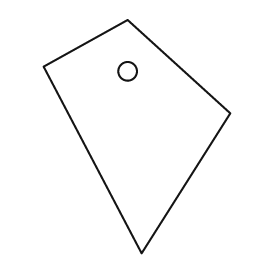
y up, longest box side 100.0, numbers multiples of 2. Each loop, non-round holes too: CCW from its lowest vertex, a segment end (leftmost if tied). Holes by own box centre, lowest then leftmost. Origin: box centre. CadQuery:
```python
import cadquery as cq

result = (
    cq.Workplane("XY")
    .moveTo(2.0, -50.0)
    .lineTo(40.0, 10.0)
    .lineTo(-4.0, 50.0)
    .lineTo(-40.0, 30.0)
    .close()
    .moveTo(-4.0, 28.0)
    .circle(4.0)
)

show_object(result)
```